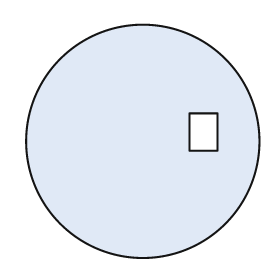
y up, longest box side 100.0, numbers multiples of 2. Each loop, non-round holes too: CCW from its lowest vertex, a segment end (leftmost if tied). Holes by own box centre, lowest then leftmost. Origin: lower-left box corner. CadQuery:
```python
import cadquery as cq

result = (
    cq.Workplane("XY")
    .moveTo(50.0, 50.0)
    .circle(50.0)
    .moveTo(70.0, 46.0)
    .lineTo(82.0, 46.0)
    .lineTo(82.0, 62.0)
    .lineTo(70.0, 62.0)
    .close()
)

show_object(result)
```